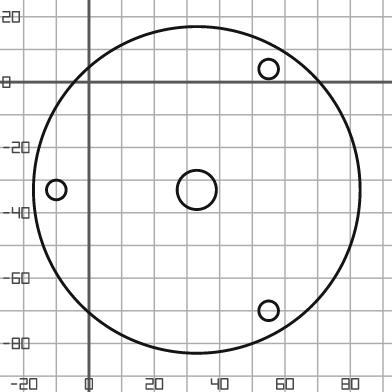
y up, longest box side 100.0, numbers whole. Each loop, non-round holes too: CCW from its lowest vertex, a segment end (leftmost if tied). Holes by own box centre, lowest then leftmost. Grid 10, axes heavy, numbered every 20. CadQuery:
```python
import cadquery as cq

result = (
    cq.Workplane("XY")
    .moveTo(33.0, -33.0)
    .circle(50.0)
    .moveTo(55.0, -70.0)
    .circle(3.0)
    .moveTo(-10.0, -33.0)
    .circle(3.0)
    .moveTo(33.0, -33.0)
    .circle(6.0)
    .moveTo(55.0, 4.0)
    .circle(3.0)
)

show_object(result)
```